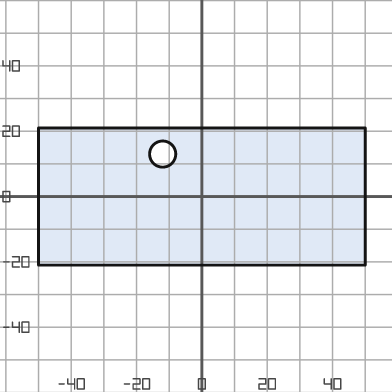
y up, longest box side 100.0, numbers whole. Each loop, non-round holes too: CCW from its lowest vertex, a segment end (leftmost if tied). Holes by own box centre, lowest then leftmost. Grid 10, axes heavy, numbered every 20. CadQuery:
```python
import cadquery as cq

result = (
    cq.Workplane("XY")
    .moveTo(-50.0, -21.0)
    .lineTo(50.0, -21.0)
    .lineTo(50.0, 21.0)
    .lineTo(-50.0, 21.0)
    .close()
    .moveTo(-12.0, 13.0)
    .circle(4.0)
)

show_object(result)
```